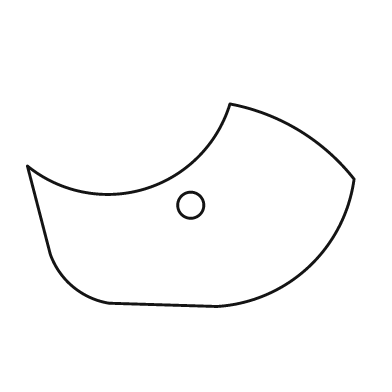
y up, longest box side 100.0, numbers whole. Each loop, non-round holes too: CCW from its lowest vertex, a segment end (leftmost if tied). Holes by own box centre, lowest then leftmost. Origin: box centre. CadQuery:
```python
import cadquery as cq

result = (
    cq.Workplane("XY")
    .moveTo(8.0, -31.0)
    .threePointArc((36.0, -19.0), (50.0, 8.0))
    .threePointArc((33.0, 23.0), (12.0, 31.0))
    .threePointArc((-14.0, 5.0), (-50.0, 12.0))
    .lineTo(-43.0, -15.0)
    .threePointArc((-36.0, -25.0), (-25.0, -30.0))
    .close()
    .moveTo(0.0, 0.0)
    .circle(4.0)
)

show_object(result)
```